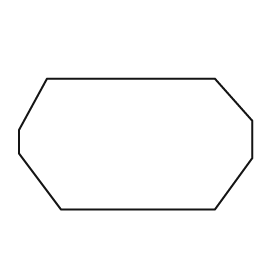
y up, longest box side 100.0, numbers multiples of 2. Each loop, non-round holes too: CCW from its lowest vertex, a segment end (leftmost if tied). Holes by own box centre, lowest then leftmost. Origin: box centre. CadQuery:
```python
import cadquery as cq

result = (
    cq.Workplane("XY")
    .moveTo(-32.0, -28.0)
    .lineTo(34.0, -28.0)
    .lineTo(50.0, -6.0)
    .lineTo(50.0, 10.0)
    .lineTo(34.0, 28.0)
    .lineTo(-38.0, 28.0)
    .lineTo(-50.0, 6.0)
    .lineTo(-50.0, -4.0)
    .close()
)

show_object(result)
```